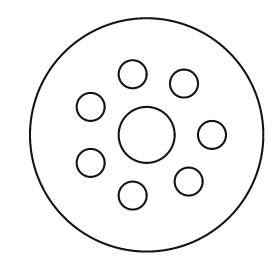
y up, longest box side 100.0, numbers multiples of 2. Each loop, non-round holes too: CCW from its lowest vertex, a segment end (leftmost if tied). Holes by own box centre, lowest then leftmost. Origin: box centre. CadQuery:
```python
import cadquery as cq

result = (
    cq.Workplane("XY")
    .moveTo(0.0, 0.0)
    .circle(50.0)
    .moveTo(-6.0, -26.0)
    .circle(6.0)
    .moveTo(18.0, -20.0)
    .circle(6.0)
    .moveTo(-24.0, -12.0)
    .circle(6.0)
    .moveTo(0.0, 0.0)
    .circle(12.0)
    .moveTo(28.0, 0.0)
    .circle(6.0)
    .moveTo(-24.0, 12.0)
    .circle(6.0)
    .moveTo(16.0, 22.0)
    .circle(6.0)
    .moveTo(-6.0, 26.0)
    .circle(6.0)
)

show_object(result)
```